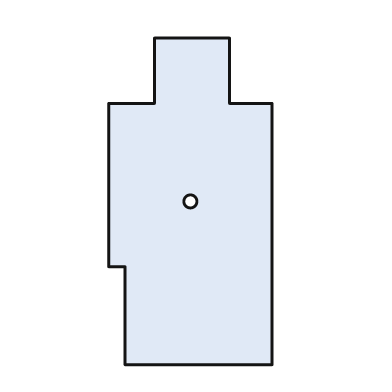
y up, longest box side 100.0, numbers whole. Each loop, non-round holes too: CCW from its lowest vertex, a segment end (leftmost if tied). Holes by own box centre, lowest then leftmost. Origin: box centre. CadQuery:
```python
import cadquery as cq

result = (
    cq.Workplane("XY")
    .moveTo(-20.0, -50.0)
    .lineTo(25.0, -50.0)
    .lineTo(25.0, 30.0)
    .lineTo(12.0, 30.0)
    .lineTo(12.0, 50.0)
    .lineTo(-11.0, 50.0)
    .lineTo(-11.0, 30.0)
    .lineTo(-25.0, 30.0)
    .lineTo(-25.0, -20.0)
    .lineTo(-20.0, -20.0)
    .close()
    .moveTo(0.0, 0.0)
    .circle(2.0)
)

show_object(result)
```